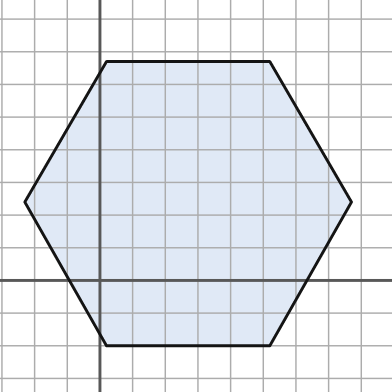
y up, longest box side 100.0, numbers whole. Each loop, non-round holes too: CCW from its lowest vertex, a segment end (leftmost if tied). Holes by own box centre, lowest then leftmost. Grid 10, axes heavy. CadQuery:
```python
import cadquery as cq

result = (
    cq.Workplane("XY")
    .moveTo(2.0, -20.0)
    .lineTo(52.0, -20.0)
    .lineTo(77.0, 24.0)
    .lineTo(52.0, 67.0)
    .lineTo(2.0, 67.0)
    .lineTo(-23.0, 24.0)
    .close()
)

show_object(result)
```